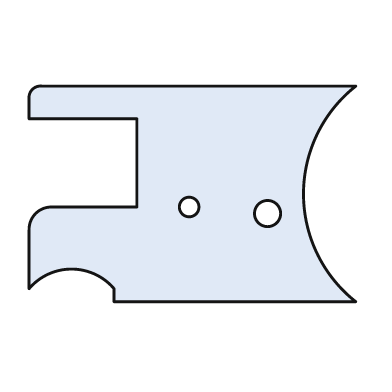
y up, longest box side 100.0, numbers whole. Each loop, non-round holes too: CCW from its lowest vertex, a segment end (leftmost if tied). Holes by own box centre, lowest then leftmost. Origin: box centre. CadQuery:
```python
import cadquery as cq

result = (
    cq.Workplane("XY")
    .moveTo(-24.0, -33.0)
    .lineTo(50.0, -33.0)
    .threePointArc((34.0, 0.0), (50.0, 33.0))
    .lineTo(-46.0, 33.0)
    .threePointArc((-49.0, 32.0), (-50.0, 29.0))
    .lineTo(-50.0, 23.0)
    .lineTo(-17.0, 23.0)
    .lineTo(-17.0, -4.0)
    .lineTo(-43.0, -4.0)
    .threePointArc((-48.0, -6.0), (-50.0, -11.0))
    .lineTo(-50.0, -29.0)
    .threePointArc((-37.0, -23.0), (-24.0, -29.0))
    .close()
    .moveTo(23.0, -6.0)
    .circle(4.0)
    .moveTo(-1.0, -4.0)
    .circle(3.0)
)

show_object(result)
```